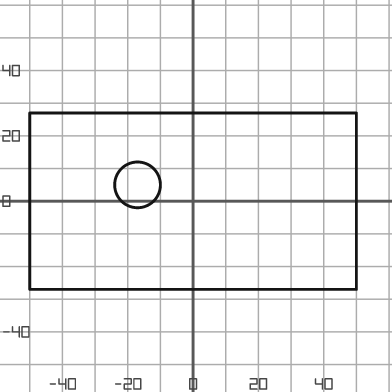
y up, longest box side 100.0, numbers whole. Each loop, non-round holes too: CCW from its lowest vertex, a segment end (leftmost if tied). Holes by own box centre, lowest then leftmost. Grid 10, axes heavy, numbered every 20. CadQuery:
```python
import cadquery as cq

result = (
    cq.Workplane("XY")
    .moveTo(-50.0, -27.0)
    .lineTo(50.0, -27.0)
    .lineTo(50.0, 27.0)
    .lineTo(-50.0, 27.0)
    .close()
    .moveTo(-17.0, 5.0)
    .circle(7.0)
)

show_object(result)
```